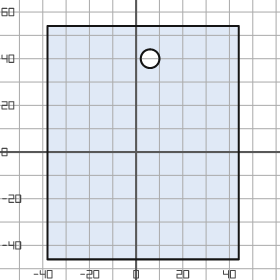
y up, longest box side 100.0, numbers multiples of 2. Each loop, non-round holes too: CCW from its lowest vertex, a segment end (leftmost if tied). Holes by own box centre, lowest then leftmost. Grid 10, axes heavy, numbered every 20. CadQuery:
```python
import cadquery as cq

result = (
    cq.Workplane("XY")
    .moveTo(-38.0, -46.0)
    .lineTo(44.0, -46.0)
    .lineTo(44.0, 54.0)
    .lineTo(-38.0, 54.0)
    .close()
    .moveTo(6.0, 40.0)
    .circle(4.0)
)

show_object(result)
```